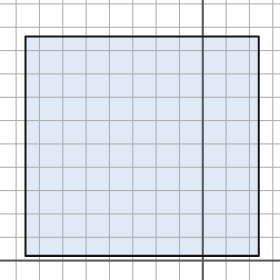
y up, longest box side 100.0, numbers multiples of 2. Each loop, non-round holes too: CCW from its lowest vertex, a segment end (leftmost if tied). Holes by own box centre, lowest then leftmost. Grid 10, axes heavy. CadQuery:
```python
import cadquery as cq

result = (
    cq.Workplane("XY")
    .moveTo(-76.0, 2.0)
    .lineTo(24.0, 2.0)
    .lineTo(24.0, 96.0)
    .lineTo(-76.0, 96.0)
    .close()
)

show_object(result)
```